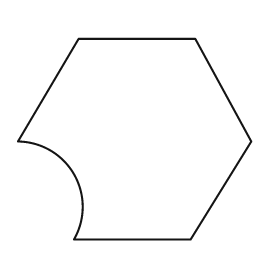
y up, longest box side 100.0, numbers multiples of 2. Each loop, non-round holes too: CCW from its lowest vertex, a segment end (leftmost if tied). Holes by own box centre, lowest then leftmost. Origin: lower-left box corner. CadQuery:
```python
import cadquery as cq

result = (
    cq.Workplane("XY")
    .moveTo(24.0, 0.0)
    .lineTo(74.0, 0.0)
    .lineTo(100.0, 42.0)
    .lineTo(76.0, 86.0)
    .lineTo(26.0, 86.0)
    .lineTo(0.0, 42.0)
    .threePointArc((24.0, 28.0), (24.0, 0.0))
    .close()
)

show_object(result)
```